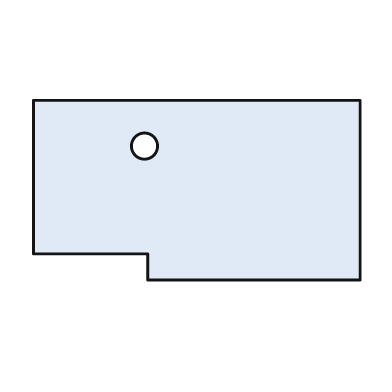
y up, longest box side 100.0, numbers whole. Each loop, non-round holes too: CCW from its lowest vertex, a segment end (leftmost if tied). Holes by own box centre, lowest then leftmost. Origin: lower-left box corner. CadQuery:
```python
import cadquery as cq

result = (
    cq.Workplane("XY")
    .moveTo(35.0, 0.0)
    .lineTo(100.0, 0.0)
    .lineTo(100.0, 55.0)
    .lineTo(0.0, 55.0)
    .lineTo(0.0, 8.0)
    .lineTo(35.0, 8.0)
    .close()
    .moveTo(34.0, 41.0)
    .circle(4.0)
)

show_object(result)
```